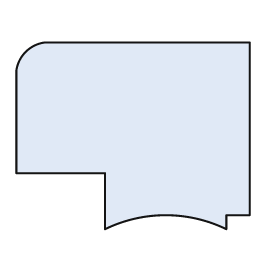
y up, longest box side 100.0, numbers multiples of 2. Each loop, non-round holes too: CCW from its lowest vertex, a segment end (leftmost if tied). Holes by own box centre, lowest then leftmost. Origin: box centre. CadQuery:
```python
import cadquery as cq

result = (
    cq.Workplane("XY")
    .moveTo(-12.0, -40.0)
    .threePointArc((14.0, -34.0), (40.0, -40.0))
    .lineTo(40.0, -34.0)
    .lineTo(50.0, -34.0)
    .lineTo(50.0, 40.0)
    .lineTo(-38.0, 40.0)
    .threePointArc((-46.0, 36.0), (-50.0, 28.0))
    .lineTo(-50.0, -16.0)
    .lineTo(-12.0, -16.0)
    .close()
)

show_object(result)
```